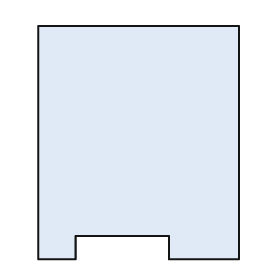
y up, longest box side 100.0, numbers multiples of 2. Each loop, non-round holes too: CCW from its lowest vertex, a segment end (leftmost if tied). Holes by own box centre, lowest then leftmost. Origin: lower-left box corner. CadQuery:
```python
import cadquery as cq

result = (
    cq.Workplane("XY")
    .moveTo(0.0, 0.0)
    .lineTo(16.0, 0.0)
    .lineTo(16.0, 10.0)
    .lineTo(56.0, 10.0)
    .lineTo(56.0, 0.0)
    .lineTo(86.0, 0.0)
    .lineTo(86.0, 100.0)
    .lineTo(0.0, 100.0)
    .close()
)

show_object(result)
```